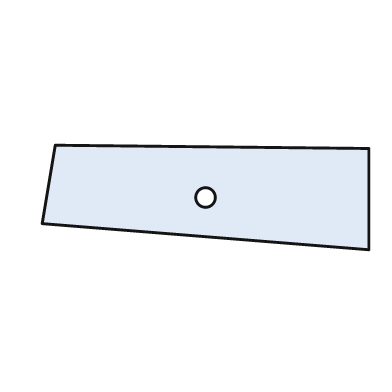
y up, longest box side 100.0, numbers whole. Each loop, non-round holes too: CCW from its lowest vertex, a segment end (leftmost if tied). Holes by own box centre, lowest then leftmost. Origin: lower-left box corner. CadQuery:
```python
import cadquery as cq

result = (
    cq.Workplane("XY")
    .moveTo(100.0, 0.0)
    .lineTo(100.0, 31.0)
    .lineTo(4.0, 32.0)
    .lineTo(0.0, 8.0)
    .close()
    .moveTo(50.0, 16.0)
    .circle(3.0)
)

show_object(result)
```